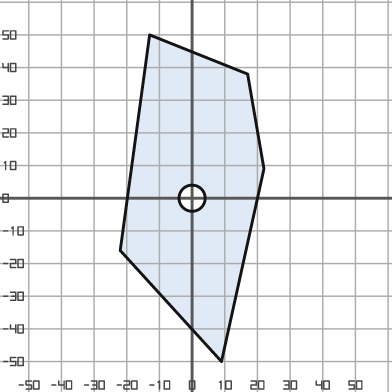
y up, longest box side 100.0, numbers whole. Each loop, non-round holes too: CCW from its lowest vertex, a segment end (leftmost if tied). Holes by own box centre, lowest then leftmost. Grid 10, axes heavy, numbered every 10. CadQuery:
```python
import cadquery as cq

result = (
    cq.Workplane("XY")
    .moveTo(9.0, -50.0)
    .lineTo(22.0, 9.0)
    .lineTo(17.0, 38.0)
    .lineTo(-13.0, 50.0)
    .lineTo(-22.0, -16.0)
    .close()
    .moveTo(0.0, 0.0)
    .circle(4.0)
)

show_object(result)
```